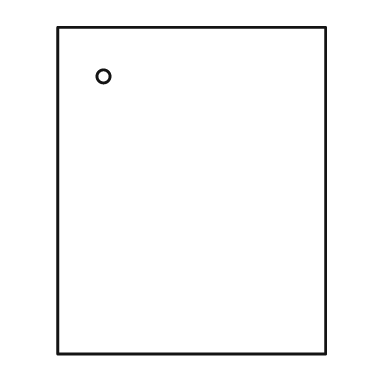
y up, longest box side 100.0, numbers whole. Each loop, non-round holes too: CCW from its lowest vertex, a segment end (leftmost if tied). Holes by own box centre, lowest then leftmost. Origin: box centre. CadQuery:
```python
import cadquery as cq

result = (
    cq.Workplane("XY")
    .moveTo(-41.0, -50.0)
    .lineTo(41.0, -50.0)
    .lineTo(41.0, 50.0)
    .lineTo(-41.0, 50.0)
    .close()
    .moveTo(-27.0, 35.0)
    .circle(2.0)
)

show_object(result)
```